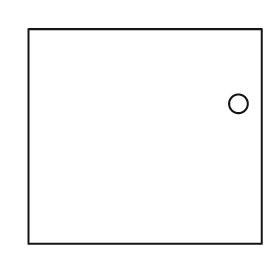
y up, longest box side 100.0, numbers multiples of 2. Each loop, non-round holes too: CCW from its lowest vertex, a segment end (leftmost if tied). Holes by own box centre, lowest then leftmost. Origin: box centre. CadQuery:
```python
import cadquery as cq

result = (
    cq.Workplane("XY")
    .moveTo(-50.0, -46.0)
    .lineTo(50.0, -46.0)
    .lineTo(50.0, 46.0)
    .lineTo(-50.0, 46.0)
    .close()
    .moveTo(40.0, 14.0)
    .circle(4.0)
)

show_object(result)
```